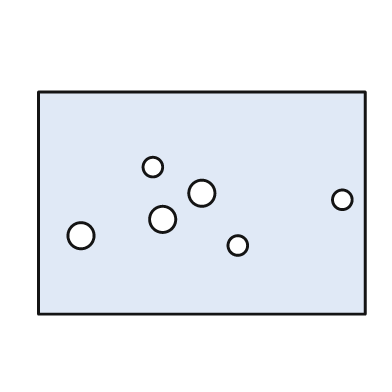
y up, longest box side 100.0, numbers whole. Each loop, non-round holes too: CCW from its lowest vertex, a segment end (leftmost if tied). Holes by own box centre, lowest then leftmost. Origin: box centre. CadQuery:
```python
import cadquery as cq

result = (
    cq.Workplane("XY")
    .moveTo(-50.0, -34.0)
    .lineTo(50.0, -34.0)
    .lineTo(50.0, 34.0)
    .lineTo(-50.0, 34.0)
    .close()
    .moveTo(11.0, -13.0)
    .circle(3.0)
    .moveTo(-37.0, -10.0)
    .circle(4.0)
    .moveTo(-12.0, -5.0)
    .circle(4.0)
    .moveTo(43.0, 1.0)
    .circle(3.0)
    .moveTo(0.0, 3.0)
    .circle(4.0)
    .moveTo(-15.0, 11.0)
    .circle(3.0)
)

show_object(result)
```